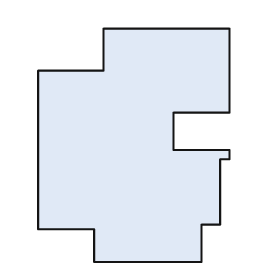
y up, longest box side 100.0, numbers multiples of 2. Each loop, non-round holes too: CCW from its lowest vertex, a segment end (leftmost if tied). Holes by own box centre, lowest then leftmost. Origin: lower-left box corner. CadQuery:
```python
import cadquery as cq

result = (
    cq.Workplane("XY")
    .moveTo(24.0, 0.0)
    .lineTo(70.0, 0.0)
    .lineTo(70.0, 16.0)
    .lineTo(78.0, 16.0)
    .lineTo(78.0, 44.0)
    .lineTo(82.0, 44.0)
    .lineTo(82.0, 48.0)
    .lineTo(58.0, 48.0)
    .lineTo(58.0, 64.0)
    .lineTo(82.0, 64.0)
    .lineTo(82.0, 100.0)
    .lineTo(28.0, 100.0)
    .lineTo(28.0, 82.0)
    .lineTo(0.0, 82.0)
    .lineTo(0.0, 14.0)
    .lineTo(24.0, 14.0)
    .close()
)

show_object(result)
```